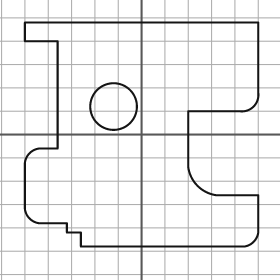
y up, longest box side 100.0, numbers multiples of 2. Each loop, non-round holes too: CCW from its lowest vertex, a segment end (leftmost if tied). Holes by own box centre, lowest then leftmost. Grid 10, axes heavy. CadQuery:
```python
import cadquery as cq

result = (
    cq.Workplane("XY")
    .moveTo(-26.0, -48.0)
    .lineTo(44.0, -48.0)
    .threePointArc((48.0, -46.0), (50.0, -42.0))
    .lineTo(50.0, -26.0)
    .lineTo(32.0, -26.0)
    .threePointArc((24.0, -22.0), (20.0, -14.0))
    .lineTo(20.0, 10.0)
    .lineTo(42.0, 10.0)
    .threePointArc((48.0, 12.0), (50.0, 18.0))
    .lineTo(50.0, 48.0)
    .lineTo(-50.0, 48.0)
    .lineTo(-50.0, 40.0)
    .lineTo(-36.0, 40.0)
    .lineTo(-36.0, -6.0)
    .lineTo(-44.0, -6.0)
    .threePointArc((-48.0, -8.0), (-50.0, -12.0))
    .lineTo(-50.0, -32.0)
    .threePointArc((-48.0, -36.0), (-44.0, -38.0))
    .lineTo(-32.0, -38.0)
    .lineTo(-32.0, -42.0)
    .lineTo(-26.0, -42.0)
    .close()
    .moveTo(-12.0, 12.0)
    .circle(10.0)
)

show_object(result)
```